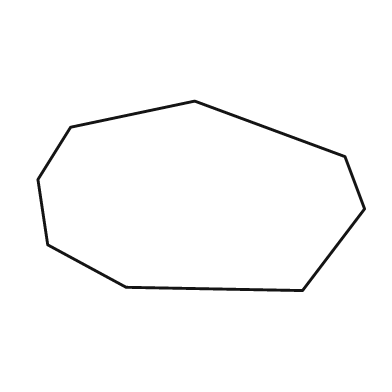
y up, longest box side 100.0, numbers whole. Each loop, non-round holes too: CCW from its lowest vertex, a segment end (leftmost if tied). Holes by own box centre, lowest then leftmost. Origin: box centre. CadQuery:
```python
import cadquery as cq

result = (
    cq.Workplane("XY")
    .moveTo(31.0, -29.0)
    .lineTo(50.0, -4.0)
    .lineTo(44.0, 12.0)
    .lineTo(-2.0, 29.0)
    .lineTo(-40.0, 21.0)
    .lineTo(-50.0, 5.0)
    .lineTo(-47.0, -15.0)
    .lineTo(-23.0, -28.0)
    .close()
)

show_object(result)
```